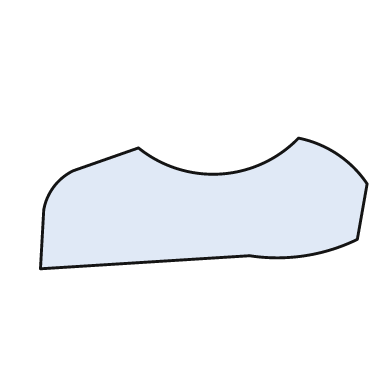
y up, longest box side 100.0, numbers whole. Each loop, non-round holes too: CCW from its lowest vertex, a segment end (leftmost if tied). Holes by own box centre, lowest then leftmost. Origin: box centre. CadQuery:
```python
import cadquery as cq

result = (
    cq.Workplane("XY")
    .moveTo(-50.0, -20.0)
    .lineTo(14.0, -16.0)
    .threePointArc((31.0, -16.0), (47.0, -11.0))
    .lineTo(50.0, 6.0)
    .threePointArc((41.0, 15.0), (29.0, 20.0))
    .threePointArc((5.0, 9.0), (-20.0, 17.0))
    .lineTo(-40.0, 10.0)
    .threePointArc((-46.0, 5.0), (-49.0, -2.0))
    .close()
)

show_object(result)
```